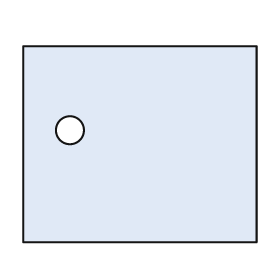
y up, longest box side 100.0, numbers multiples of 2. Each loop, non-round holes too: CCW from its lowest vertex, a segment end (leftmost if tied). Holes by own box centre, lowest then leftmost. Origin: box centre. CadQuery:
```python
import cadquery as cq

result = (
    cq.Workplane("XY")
    .moveTo(-50.0, -42.0)
    .lineTo(50.0, -42.0)
    .lineTo(50.0, 42.0)
    .lineTo(-50.0, 42.0)
    .close()
    .moveTo(-30.0, 6.0)
    .circle(6.0)
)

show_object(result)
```